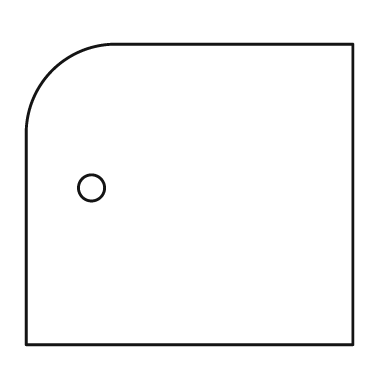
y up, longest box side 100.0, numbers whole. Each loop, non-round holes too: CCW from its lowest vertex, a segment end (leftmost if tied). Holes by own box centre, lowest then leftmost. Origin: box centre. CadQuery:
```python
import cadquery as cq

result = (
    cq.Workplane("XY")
    .moveTo(-50.0, -46.0)
    .lineTo(50.0, -46.0)
    .lineTo(50.0, 46.0)
    .lineTo(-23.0, 46.0)
    .threePointArc((-42.0, 38.0), (-50.0, 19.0))
    .close()
    .moveTo(-30.0, 2.0)
    .circle(4.0)
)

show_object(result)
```